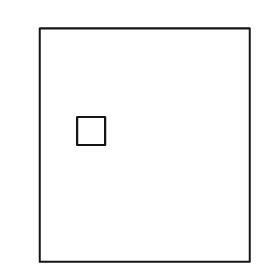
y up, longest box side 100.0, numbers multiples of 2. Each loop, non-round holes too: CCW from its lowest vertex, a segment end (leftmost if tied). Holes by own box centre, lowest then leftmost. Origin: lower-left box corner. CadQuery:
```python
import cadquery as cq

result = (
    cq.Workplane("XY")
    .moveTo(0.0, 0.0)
    .lineTo(90.0, 0.0)
    .lineTo(90.0, 100.0)
    .lineTo(0.0, 100.0)
    .close()
    .moveTo(16.0, 50.0)
    .lineTo(28.0, 50.0)
    .lineTo(28.0, 62.0)
    .lineTo(16.0, 62.0)
    .close()
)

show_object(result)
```